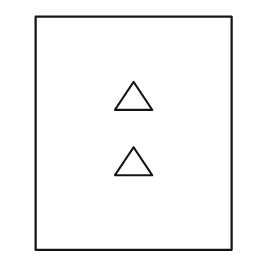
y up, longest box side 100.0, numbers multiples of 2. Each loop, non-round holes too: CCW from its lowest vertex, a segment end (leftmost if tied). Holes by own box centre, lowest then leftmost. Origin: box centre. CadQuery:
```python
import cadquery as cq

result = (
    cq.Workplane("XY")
    .moveTo(-42.0, -50.0)
    .lineTo(42.0, -50.0)
    .lineTo(42.0, 50.0)
    .lineTo(-42.0, 50.0)
    .close()
    .moveTo(-8.0, -18.0)
    .lineTo(8.0, -18.0)
    .lineTo(0.0, -6.0)
    .close()
    .moveTo(-8.0, 10.0)
    .lineTo(8.0, 10.0)
    .lineTo(0.0, 22.0)
    .close()
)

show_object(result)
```